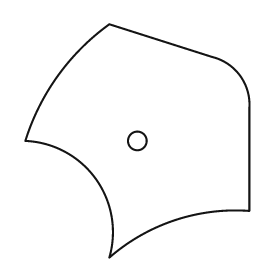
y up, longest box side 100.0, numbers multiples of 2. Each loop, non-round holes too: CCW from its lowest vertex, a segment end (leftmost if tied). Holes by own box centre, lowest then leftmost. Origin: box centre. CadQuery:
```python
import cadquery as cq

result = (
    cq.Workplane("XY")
    .moveTo(-12.0, -50.0)
    .threePointArc((16.0, -34.0), (48.0, -30.0))
    .lineTo(48.0, 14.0)
    .threePointArc((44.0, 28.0), (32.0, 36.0))
    .lineTo(-12.0, 50.0)
    .threePointArc((-34.0, 28.0), (-48.0, 0.0))
    .threePointArc((-18.0, -16.0), (-12.0, -50.0))
    .close()
    .moveTo(0.0, 0.0)
    .circle(4.0)
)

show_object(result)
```